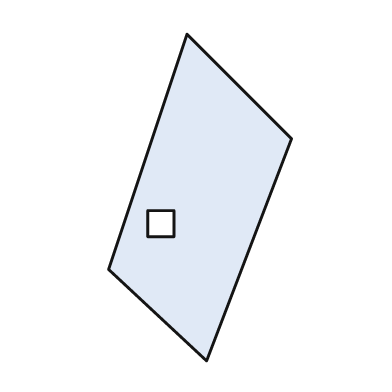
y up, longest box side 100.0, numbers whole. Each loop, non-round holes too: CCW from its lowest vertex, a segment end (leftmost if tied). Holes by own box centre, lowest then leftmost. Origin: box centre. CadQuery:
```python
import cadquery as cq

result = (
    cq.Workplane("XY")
    .moveTo(2.0, -50.0)
    .lineTo(28.0, 18.0)
    .lineTo(-4.0, 50.0)
    .lineTo(-28.0, -22.0)
    .close()
    .moveTo(-16.0, -12.0)
    .lineTo(-8.0, -12.0)
    .lineTo(-8.0, -4.0)
    .lineTo(-16.0, -4.0)
    .close()
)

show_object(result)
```